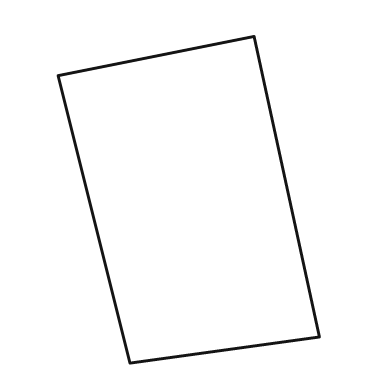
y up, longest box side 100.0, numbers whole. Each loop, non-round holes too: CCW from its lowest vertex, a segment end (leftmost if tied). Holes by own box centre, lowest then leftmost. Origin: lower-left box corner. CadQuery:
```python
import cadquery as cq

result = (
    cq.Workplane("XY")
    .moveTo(22.0, 0.0)
    .lineTo(80.0, 8.0)
    .lineTo(60.0, 100.0)
    .lineTo(0.0, 88.0)
    .close()
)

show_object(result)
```